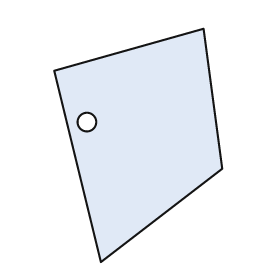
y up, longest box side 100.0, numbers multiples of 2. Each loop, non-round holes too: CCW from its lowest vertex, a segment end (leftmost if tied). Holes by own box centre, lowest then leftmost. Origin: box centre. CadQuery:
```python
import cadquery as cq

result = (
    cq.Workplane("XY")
    .moveTo(-16.0, -50.0)
    .lineTo(36.0, -10.0)
    .lineTo(28.0, 50.0)
    .lineTo(-36.0, 32.0)
    .close()
    .moveTo(-22.0, 10.0)
    .circle(4.0)
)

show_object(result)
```